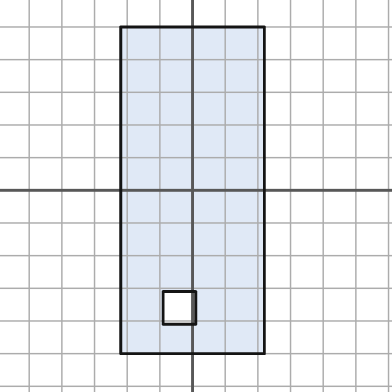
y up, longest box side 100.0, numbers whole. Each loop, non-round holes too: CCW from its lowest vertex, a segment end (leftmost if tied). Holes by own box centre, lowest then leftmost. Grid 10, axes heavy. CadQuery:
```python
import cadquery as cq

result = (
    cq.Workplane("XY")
    .moveTo(-22.0, -50.0)
    .lineTo(22.0, -50.0)
    .lineTo(22.0, 50.0)
    .lineTo(-22.0, 50.0)
    .close()
    .moveTo(-9.0, -41.0)
    .lineTo(1.0, -41.0)
    .lineTo(1.0, -31.0)
    .lineTo(-9.0, -31.0)
    .close()
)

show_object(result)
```